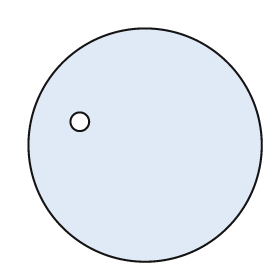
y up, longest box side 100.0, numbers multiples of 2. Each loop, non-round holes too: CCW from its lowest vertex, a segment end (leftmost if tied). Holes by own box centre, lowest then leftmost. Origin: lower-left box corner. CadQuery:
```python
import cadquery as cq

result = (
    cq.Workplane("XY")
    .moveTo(50.0, 50.0)
    .circle(50.0)
    .moveTo(22.0, 60.0)
    .circle(4.0)
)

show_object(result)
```